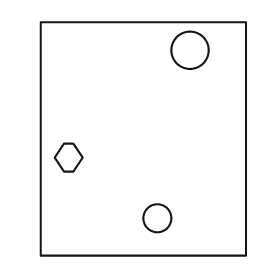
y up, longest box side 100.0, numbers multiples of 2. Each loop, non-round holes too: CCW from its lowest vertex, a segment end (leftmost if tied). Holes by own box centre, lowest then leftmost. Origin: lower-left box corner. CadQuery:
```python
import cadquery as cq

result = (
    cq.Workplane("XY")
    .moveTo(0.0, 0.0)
    .lineTo(88.0, 0.0)
    .lineTo(88.0, 100.0)
    .lineTo(0.0, 100.0)
    .close()
    .moveTo(50.0, 16.0)
    .circle(6.0)
    .moveTo(10.0, 36.0)
    .lineTo(14.0, 36.0)
    .lineTo(18.0, 42.0)
    .lineTo(14.0, 48.0)
    .lineTo(10.0, 48.0)
    .lineTo(6.0, 42.0)
    .close()
    .moveTo(64.0, 88.0)
    .circle(8.0)
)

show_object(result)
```